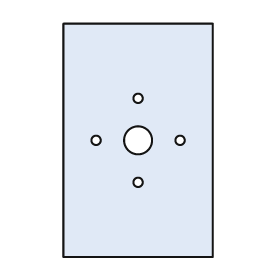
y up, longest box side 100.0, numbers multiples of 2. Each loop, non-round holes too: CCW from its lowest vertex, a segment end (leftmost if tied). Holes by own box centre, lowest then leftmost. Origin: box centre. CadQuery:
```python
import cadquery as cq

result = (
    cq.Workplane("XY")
    .moveTo(-32.0, -50.0)
    .lineTo(32.0, -50.0)
    .lineTo(32.0, 50.0)
    .lineTo(-32.0, 50.0)
    .close()
    .moveTo(0.0, -18.0)
    .circle(2.0)
    .moveTo(-18.0, 0.0)
    .circle(2.0)
    .moveTo(0.0, 0.0)
    .circle(6.0)
    .moveTo(18.0, 0.0)
    .circle(2.0)
    .moveTo(0.0, 18.0)
    .circle(2.0)
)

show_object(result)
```